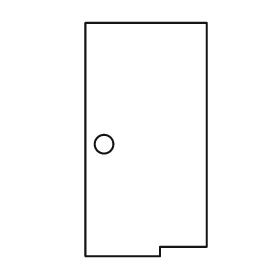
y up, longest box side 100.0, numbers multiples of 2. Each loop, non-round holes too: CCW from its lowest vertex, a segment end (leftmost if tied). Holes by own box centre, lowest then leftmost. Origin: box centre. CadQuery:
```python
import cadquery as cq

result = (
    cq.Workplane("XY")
    .moveTo(-26.0, -50.0)
    .lineTo(6.0, -50.0)
    .lineTo(6.0, -46.0)
    .lineTo(26.0, -46.0)
    .lineTo(26.0, 50.0)
    .lineTo(-26.0, 50.0)
    .close()
    .moveTo(-18.0, -2.0)
    .circle(4.0)
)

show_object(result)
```